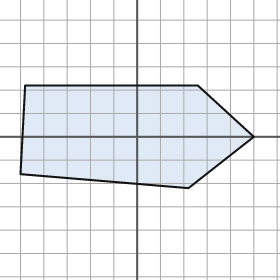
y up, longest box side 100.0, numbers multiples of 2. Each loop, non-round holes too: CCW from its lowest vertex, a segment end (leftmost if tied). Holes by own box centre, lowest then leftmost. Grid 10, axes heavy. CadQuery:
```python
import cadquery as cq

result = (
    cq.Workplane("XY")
    .moveTo(22.0, -22.0)
    .lineTo(50.0, 0.0)
    .lineTo(26.0, 22.0)
    .lineTo(-48.0, 22.0)
    .lineTo(-50.0, -16.0)
    .close()
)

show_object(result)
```